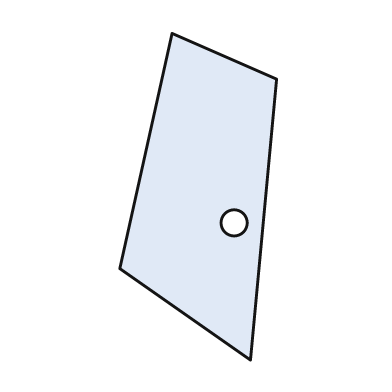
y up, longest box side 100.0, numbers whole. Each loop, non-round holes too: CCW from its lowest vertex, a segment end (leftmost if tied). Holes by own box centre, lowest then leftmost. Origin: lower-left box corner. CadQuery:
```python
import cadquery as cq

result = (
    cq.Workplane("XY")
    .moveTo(40.0, 0.0)
    .lineTo(48.0, 86.0)
    .lineTo(16.0, 100.0)
    .lineTo(0.0, 28.0)
    .close()
    .moveTo(35.0, 42.0)
    .circle(4.0)
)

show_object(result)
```